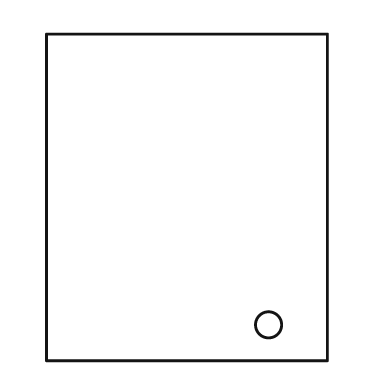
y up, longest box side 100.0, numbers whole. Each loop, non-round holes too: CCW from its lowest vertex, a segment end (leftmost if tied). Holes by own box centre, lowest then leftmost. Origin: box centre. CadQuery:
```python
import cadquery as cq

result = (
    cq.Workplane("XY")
    .moveTo(-43.0, -50.0)
    .lineTo(43.0, -50.0)
    .lineTo(43.0, 50.0)
    .lineTo(-43.0, 50.0)
    .close()
    .moveTo(25.0, -39.0)
    .circle(4.0)
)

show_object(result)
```